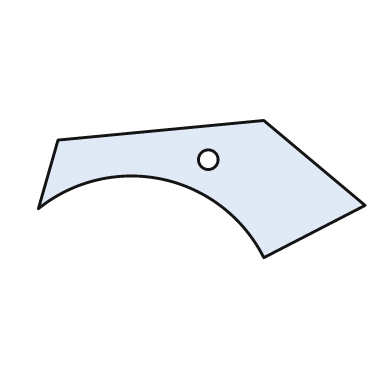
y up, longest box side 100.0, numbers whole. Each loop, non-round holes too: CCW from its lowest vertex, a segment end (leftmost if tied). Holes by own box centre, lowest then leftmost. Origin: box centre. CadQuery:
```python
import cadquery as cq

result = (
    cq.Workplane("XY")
    .moveTo(19.0, -21.0)
    .lineTo(50.0, -5.0)
    .lineTo(19.0, 21.0)
    .lineTo(-44.0, 15.0)
    .lineTo(-50.0, -6.0)
    .threePointArc((-12.0, 3.0), (19.0, -21.0))
    .close()
    .moveTo(2.0, 9.0)
    .circle(3.0)
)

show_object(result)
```